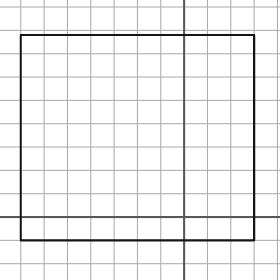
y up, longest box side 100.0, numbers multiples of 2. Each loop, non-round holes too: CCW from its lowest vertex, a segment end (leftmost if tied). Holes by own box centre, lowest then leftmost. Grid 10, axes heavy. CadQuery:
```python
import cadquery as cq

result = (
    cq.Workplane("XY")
    .moveTo(-70.0, -10.0)
    .lineTo(30.0, -10.0)
    .lineTo(30.0, 78.0)
    .lineTo(-70.0, 78.0)
    .close()
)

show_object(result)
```